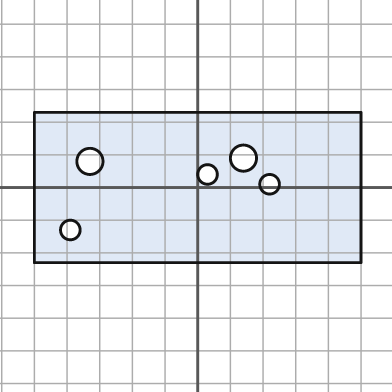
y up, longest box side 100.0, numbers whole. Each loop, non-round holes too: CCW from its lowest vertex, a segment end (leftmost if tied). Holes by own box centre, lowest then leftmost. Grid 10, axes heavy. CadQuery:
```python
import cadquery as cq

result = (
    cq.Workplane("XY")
    .moveTo(-50.0, -23.0)
    .lineTo(50.0, -23.0)
    .lineTo(50.0, 23.0)
    .lineTo(-50.0, 23.0)
    .close()
    .moveTo(-39.0, -13.0)
    .circle(3.0)
    .moveTo(22.0, 1.0)
    .circle(3.0)
    .moveTo(3.0, 4.0)
    .circle(3.0)
    .moveTo(-33.0, 8.0)
    .circle(4.0)
    .moveTo(14.0, 9.0)
    .circle(4.0)
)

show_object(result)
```